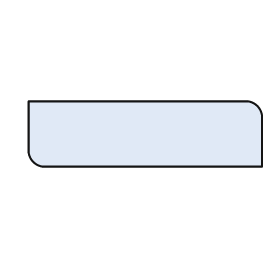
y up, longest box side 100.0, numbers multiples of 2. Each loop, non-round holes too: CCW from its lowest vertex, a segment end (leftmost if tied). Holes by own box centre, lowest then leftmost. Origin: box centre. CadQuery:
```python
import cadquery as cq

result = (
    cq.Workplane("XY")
    .moveTo(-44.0, -14.0)
    .lineTo(50.0, -14.0)
    .lineTo(50.0, 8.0)
    .threePointArc((48.0, 12.0), (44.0, 14.0))
    .lineTo(-50.0, 14.0)
    .lineTo(-50.0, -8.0)
    .threePointArc((-48.0, -12.0), (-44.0, -14.0))
    .close()
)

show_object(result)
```